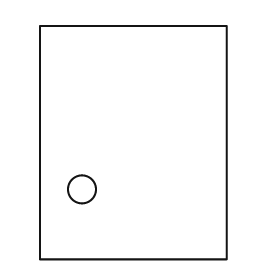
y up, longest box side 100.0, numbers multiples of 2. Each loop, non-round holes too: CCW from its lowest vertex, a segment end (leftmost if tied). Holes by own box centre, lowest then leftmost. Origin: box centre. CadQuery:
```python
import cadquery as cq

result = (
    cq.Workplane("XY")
    .moveTo(-40.0, -50.0)
    .lineTo(40.0, -50.0)
    .lineTo(40.0, 50.0)
    .lineTo(-40.0, 50.0)
    .close()
    .moveTo(-22.0, -20.0)
    .circle(6.0)
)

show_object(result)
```